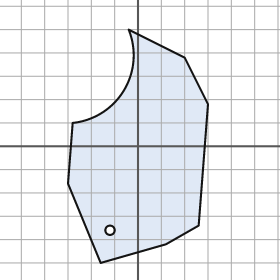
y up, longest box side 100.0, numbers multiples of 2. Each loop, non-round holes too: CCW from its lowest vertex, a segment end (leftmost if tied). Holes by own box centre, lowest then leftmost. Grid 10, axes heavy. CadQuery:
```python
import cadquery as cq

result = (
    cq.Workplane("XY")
    .moveTo(-16.0, -50.0)
    .lineTo(12.0, -42.0)
    .lineTo(26.0, -34.0)
    .lineTo(30.0, 18.0)
    .lineTo(20.0, 38.0)
    .lineTo(-4.0, 50.0)
    .threePointArc((-6.0, 24.0), (-28.0, 10.0))
    .lineTo(-30.0, -16.0)
    .close()
    .moveTo(-12.0, -36.0)
    .circle(2.0)
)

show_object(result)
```